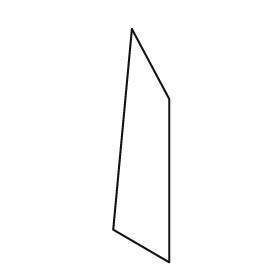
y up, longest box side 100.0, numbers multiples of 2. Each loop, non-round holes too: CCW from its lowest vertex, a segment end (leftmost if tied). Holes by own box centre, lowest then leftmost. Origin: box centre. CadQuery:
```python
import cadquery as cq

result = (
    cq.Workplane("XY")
    .moveTo(12.0, -50.0)
    .lineTo(12.0, 20.0)
    .lineTo(-4.0, 50.0)
    .lineTo(-12.0, -36.0)
    .close()
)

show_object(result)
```